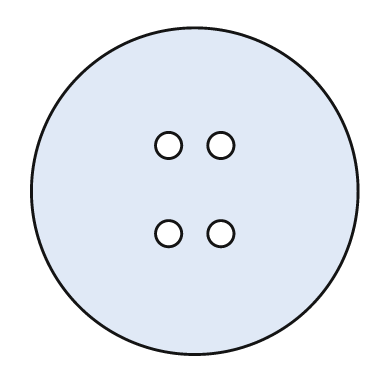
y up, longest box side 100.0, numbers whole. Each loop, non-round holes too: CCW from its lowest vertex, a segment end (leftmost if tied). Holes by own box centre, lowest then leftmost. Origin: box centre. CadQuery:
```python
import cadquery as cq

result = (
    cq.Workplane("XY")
    .moveTo(0.0, 0.0)
    .circle(50.0)
    .moveTo(-8.0, -13.0)
    .circle(4.0)
    .moveTo(8.0, -13.0)
    .circle(4.0)
    .moveTo(-8.0, 14.0)
    .circle(4.0)
    .moveTo(8.0, 14.0)
    .circle(4.0)
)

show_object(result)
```